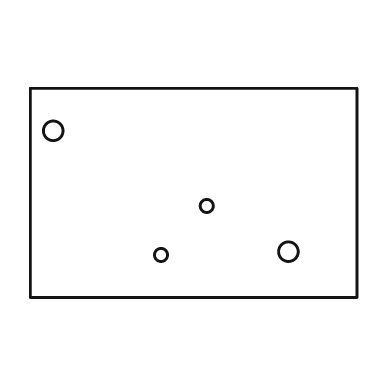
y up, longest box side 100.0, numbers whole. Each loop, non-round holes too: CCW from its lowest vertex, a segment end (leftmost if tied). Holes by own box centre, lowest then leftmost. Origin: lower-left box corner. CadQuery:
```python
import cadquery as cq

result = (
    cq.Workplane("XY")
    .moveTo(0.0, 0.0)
    .lineTo(100.0, 0.0)
    .lineTo(100.0, 64.0)
    .lineTo(0.0, 64.0)
    .close()
    .moveTo(40.0, 13.0)
    .circle(2.0)
    .moveTo(79.0, 14.0)
    .circle(3.0)
    .moveTo(54.0, 28.0)
    .circle(2.0)
    .moveTo(7.0, 51.0)
    .circle(3.0)
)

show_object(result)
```